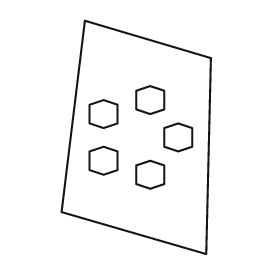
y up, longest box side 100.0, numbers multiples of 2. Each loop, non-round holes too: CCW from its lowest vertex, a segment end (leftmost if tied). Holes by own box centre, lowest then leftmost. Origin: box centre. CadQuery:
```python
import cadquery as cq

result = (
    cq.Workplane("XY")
    .moveTo(30.0, -50.0)
    .lineTo(32.0, 34.0)
    .lineTo(-22.0, 50.0)
    .lineTo(-32.0, -32.0)
    .close()
    .moveTo(6.0, -22.0)
    .lineTo(12.0, -20.0)
    .lineTo(12.0, -12.0)
    .lineTo(6.0, -10.0)
    .lineTo(0.0, -12.0)
    .lineTo(0.0, -20.0)
    .close()
    .moveTo(-14.0, -16.0)
    .lineTo(-8.0, -14.0)
    .lineTo(-8.0, -6.0)
    .lineTo(-14.0, -4.0)
    .lineTo(-20.0, -6.0)
    .lineTo(-20.0, -14.0)
    .close()
    .moveTo(18.0, -6.0)
    .lineTo(24.0, -4.0)
    .lineTo(24.0, 4.0)
    .lineTo(18.0, 6.0)
    .lineTo(12.0, 4.0)
    .lineTo(12.0, -4.0)
    .close()
    .moveTo(-14.0, 4.0)
    .lineTo(-8.0, 6.0)
    .lineTo(-8.0, 14.0)
    .lineTo(-14.0, 16.0)
    .lineTo(-20.0, 14.0)
    .lineTo(-20.0, 6.0)
    .close()
    .moveTo(6.0, 10.0)
    .lineTo(12.0, 12.0)
    .lineTo(12.0, 20.0)
    .lineTo(6.0, 22.0)
    .lineTo(0.0, 20.0)
    .lineTo(0.0, 12.0)
    .close()
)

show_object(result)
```